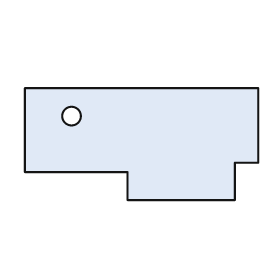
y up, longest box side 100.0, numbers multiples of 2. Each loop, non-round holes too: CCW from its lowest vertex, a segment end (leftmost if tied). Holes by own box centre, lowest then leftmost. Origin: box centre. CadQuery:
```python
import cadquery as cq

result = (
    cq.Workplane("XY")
    .moveTo(-6.0, -24.0)
    .lineTo(40.0, -24.0)
    .lineTo(40.0, -8.0)
    .lineTo(50.0, -8.0)
    .lineTo(50.0, 24.0)
    .lineTo(-50.0, 24.0)
    .lineTo(-50.0, -12.0)
    .lineTo(-6.0, -12.0)
    .close()
    .moveTo(-30.0, 12.0)
    .circle(4.0)
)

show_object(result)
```